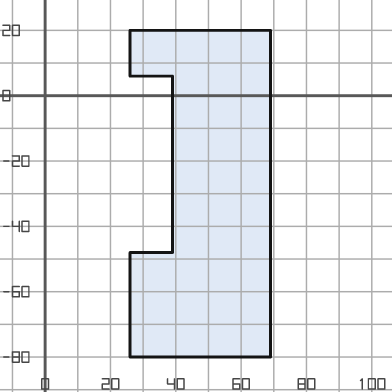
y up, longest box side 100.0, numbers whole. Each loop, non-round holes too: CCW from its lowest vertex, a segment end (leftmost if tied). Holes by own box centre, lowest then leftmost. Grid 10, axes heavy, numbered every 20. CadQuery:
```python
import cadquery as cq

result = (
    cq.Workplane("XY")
    .moveTo(26.0, -80.0)
    .lineTo(69.0, -80.0)
    .lineTo(69.0, 20.0)
    .lineTo(26.0, 20.0)
    .lineTo(26.0, 6.0)
    .lineTo(39.0, 6.0)
    .lineTo(39.0, -48.0)
    .lineTo(26.0, -48.0)
    .close()
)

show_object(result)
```